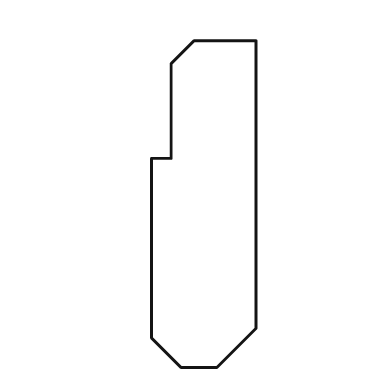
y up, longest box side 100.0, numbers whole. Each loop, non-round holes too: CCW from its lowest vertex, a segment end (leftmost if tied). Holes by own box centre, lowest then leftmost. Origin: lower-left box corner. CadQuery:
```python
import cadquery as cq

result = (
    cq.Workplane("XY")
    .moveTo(9.0, 0.0)
    .lineTo(20.0, 0.0)
    .lineTo(32.0, 12.0)
    .lineTo(32.0, 100.0)
    .lineTo(13.0, 100.0)
    .lineTo(6.0, 93.0)
    .lineTo(6.0, 64.0)
    .lineTo(0.0, 64.0)
    .lineTo(0.0, 9.0)
    .close()
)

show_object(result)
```